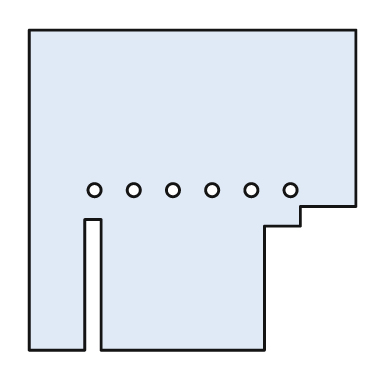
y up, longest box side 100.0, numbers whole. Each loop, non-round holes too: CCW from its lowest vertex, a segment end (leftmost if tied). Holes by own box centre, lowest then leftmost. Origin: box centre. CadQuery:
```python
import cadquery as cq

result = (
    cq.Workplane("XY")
    .moveTo(-50.0, -49.0)
    .lineTo(-33.0, -49.0)
    .lineTo(-33.0, -9.0)
    .lineTo(-28.0, -9.0)
    .lineTo(-28.0, -49.0)
    .lineTo(22.0, -49.0)
    .lineTo(22.0, -11.0)
    .lineTo(33.0, -11.0)
    .lineTo(33.0, -5.0)
    .lineTo(50.0, -5.0)
    .lineTo(50.0, 49.0)
    .lineTo(-50.0, 49.0)
    .close()
    .moveTo(-30.0, 0.0)
    .circle(2.0)
    .moveTo(-18.0, 0.0)
    .circle(2.0)
    .moveTo(-6.0, 0.0)
    .circle(2.0)
    .moveTo(6.0, 0.0)
    .circle(2.0)
    .moveTo(18.0, 0.0)
    .circle(2.0)
    .moveTo(30.0, 0.0)
    .circle(2.0)
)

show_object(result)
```